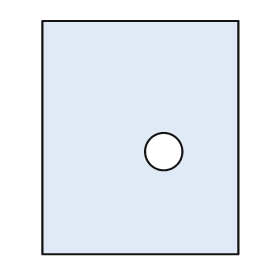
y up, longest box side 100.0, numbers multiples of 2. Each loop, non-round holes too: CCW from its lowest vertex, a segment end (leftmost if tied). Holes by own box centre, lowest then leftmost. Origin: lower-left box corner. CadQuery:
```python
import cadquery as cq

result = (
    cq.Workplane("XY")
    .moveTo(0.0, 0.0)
    .lineTo(84.0, 0.0)
    .lineTo(84.0, 100.0)
    .lineTo(0.0, 100.0)
    .close()
    .moveTo(52.0, 44.0)
    .circle(8.0)
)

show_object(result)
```